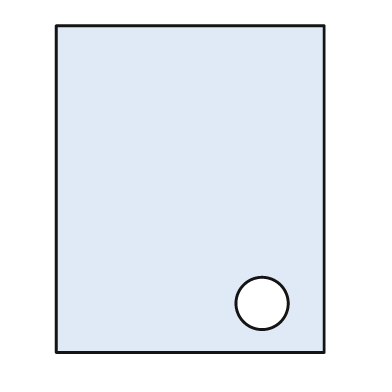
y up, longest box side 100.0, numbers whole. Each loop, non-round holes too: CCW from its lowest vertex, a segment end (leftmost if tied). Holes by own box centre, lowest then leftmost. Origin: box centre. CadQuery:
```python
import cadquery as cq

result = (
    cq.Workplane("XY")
    .moveTo(-41.0, -50.0)
    .lineTo(41.0, -50.0)
    .lineTo(41.0, 50.0)
    .lineTo(-41.0, 50.0)
    .close()
    .moveTo(22.0, -35.0)
    .circle(8.0)
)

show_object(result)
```